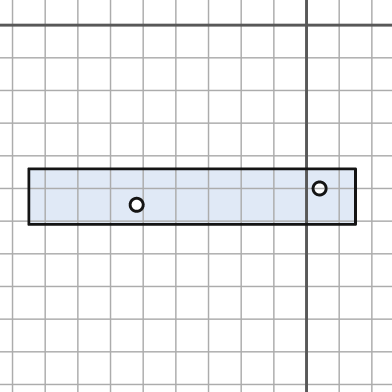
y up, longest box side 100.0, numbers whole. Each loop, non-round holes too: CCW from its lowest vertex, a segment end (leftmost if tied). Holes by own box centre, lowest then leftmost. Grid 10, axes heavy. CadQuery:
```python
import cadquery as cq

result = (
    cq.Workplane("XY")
    .moveTo(-85.0, -61.0)
    .lineTo(15.0, -61.0)
    .lineTo(15.0, -44.0)
    .lineTo(-85.0, -44.0)
    .close()
    .moveTo(-52.0, -55.0)
    .circle(2.0)
    .moveTo(4.0, -50.0)
    .circle(2.0)
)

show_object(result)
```